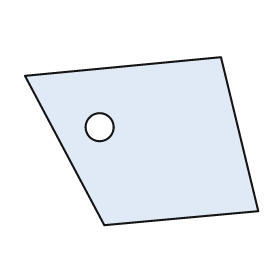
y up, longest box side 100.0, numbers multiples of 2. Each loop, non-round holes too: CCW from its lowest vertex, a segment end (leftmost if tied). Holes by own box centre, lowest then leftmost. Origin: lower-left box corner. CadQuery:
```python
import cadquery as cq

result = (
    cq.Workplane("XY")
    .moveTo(34.0, 0.0)
    .lineTo(100.0, 6.0)
    .lineTo(84.0, 72.0)
    .lineTo(0.0, 64.0)
    .close()
    .moveTo(32.0, 42.0)
    .circle(6.0)
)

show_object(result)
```